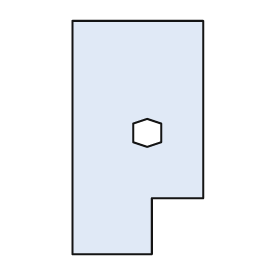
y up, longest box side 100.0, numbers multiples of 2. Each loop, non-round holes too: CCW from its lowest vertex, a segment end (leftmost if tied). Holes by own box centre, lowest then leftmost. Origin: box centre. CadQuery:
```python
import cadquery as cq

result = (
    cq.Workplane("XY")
    .moveTo(-28.0, -50.0)
    .lineTo(6.0, -50.0)
    .lineTo(6.0, -26.0)
    .lineTo(28.0, -26.0)
    .lineTo(28.0, 50.0)
    .lineTo(-28.0, 50.0)
    .close()
    .moveTo(4.0, -4.0)
    .lineTo(10.0, -2.0)
    .lineTo(10.0, 6.0)
    .lineTo(4.0, 8.0)
    .lineTo(-2.0, 6.0)
    .lineTo(-2.0, -2.0)
    .close()
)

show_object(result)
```